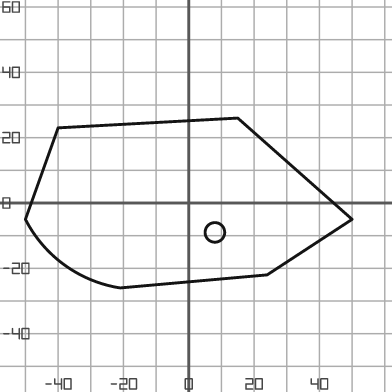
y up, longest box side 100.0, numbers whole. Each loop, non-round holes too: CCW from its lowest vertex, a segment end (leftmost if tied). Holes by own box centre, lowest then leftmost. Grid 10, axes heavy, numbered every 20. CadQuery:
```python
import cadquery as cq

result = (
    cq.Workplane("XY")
    .moveTo(-21.0, -26.0)
    .lineTo(24.0, -22.0)
    .lineTo(50.0, -5.0)
    .lineTo(15.0, 26.0)
    .lineTo(-40.0, 23.0)
    .lineTo(-50.0, -5.0)
    .threePointArc((-38.0, -19.0), (-21.0, -26.0))
    .close()
    .moveTo(8.0, -9.0)
    .circle(3.0)
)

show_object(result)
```